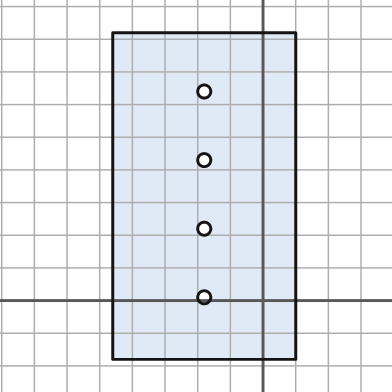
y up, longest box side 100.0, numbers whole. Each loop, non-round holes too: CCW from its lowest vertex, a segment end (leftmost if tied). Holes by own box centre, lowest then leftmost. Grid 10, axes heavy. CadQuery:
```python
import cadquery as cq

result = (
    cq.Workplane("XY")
    .moveTo(-46.0, -18.0)
    .lineTo(10.0, -18.0)
    .lineTo(10.0, 82.0)
    .lineTo(-46.0, 82.0)
    .close()
    .moveTo(-18.0, 1.0)
    .circle(2.0)
    .moveTo(-18.0, 22.0)
    .circle(2.0)
    .moveTo(-18.0, 43.0)
    .circle(2.0)
    .moveTo(-18.0, 64.0)
    .circle(2.0)
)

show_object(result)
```